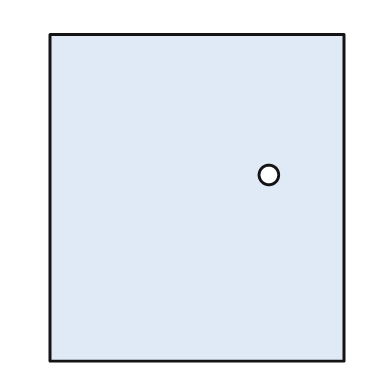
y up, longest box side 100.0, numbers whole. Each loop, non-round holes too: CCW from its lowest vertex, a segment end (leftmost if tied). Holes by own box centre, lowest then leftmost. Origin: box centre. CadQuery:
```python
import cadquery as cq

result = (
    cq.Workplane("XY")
    .moveTo(-45.0, -50.0)
    .lineTo(45.0, -50.0)
    .lineTo(45.0, 50.0)
    .lineTo(-45.0, 50.0)
    .close()
    .moveTo(22.0, 7.0)
    .circle(3.0)
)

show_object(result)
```